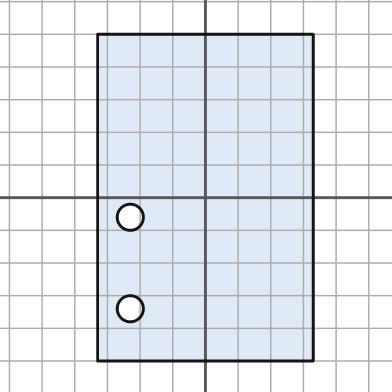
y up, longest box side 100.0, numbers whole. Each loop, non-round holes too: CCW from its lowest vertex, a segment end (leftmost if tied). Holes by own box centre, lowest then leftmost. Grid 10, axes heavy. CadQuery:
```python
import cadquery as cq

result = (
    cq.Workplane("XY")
    .moveTo(-33.0, -50.0)
    .lineTo(33.0, -50.0)
    .lineTo(33.0, 50.0)
    .lineTo(-33.0, 50.0)
    .close()
    .moveTo(-23.0, -34.0)
    .circle(4.0)
    .moveTo(-23.0, -6.0)
    .circle(4.0)
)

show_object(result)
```